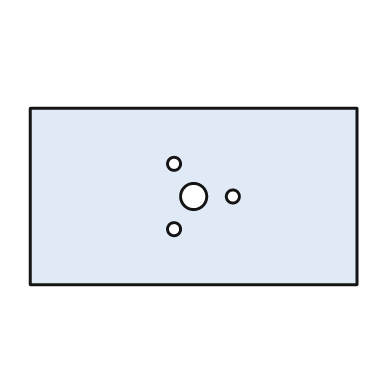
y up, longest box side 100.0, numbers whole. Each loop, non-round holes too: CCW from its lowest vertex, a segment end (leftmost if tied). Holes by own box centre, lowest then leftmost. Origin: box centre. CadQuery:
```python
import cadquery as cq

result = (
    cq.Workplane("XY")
    .moveTo(-50.0, -27.0)
    .lineTo(50.0, -27.0)
    .lineTo(50.0, 27.0)
    .lineTo(-50.0, 27.0)
    .close()
    .moveTo(-6.0, -10.0)
    .circle(2.0)
    .moveTo(0.0, 0.0)
    .circle(4.0)
    .moveTo(12.0, 0.0)
    .circle(2.0)
    .moveTo(-6.0, 10.0)
    .circle(2.0)
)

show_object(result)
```